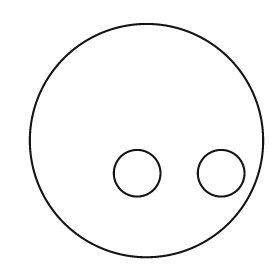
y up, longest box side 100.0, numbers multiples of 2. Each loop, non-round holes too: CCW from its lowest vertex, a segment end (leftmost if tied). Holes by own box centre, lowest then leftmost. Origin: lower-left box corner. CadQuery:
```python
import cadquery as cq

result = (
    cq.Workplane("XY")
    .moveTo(50.0, 50.0)
    .circle(50.0)
    .moveTo(46.0, 36.0)
    .circle(10.0)
    .moveTo(82.0, 36.0)
    .circle(10.0)
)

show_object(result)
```